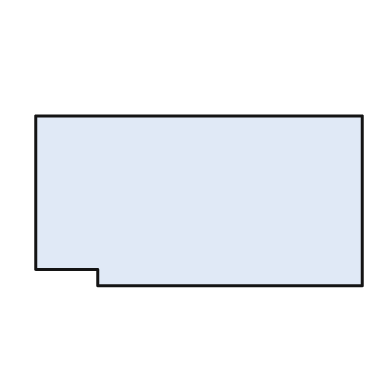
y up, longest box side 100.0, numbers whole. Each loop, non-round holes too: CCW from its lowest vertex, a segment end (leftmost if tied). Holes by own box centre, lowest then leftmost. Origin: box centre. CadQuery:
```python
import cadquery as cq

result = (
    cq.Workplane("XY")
    .moveTo(-31.0, -26.0)
    .lineTo(50.0, -26.0)
    .lineTo(50.0, 26.0)
    .lineTo(-50.0, 26.0)
    .lineTo(-50.0, -21.0)
    .lineTo(-31.0, -21.0)
    .close()
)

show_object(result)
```